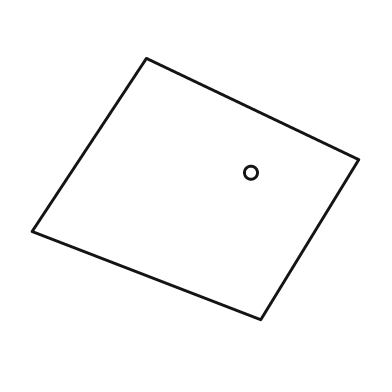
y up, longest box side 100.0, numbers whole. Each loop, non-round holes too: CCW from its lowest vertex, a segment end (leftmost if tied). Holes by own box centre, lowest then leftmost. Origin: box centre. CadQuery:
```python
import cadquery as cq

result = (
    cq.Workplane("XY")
    .moveTo(20.0, -40.0)
    .lineTo(50.0, 9.0)
    .lineTo(-15.0, 40.0)
    .lineTo(-50.0, -13.0)
    .close()
    .moveTo(17.0, 5.0)
    .circle(2.0)
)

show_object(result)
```